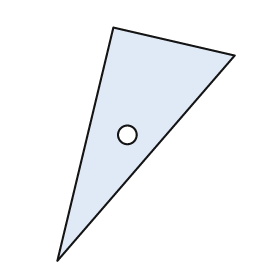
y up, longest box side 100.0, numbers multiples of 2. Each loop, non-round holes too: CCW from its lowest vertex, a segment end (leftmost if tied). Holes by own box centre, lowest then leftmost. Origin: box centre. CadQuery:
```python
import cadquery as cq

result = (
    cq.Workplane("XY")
    .moveTo(-38.0, -50.0)
    .lineTo(38.0, 38.0)
    .lineTo(-14.0, 50.0)
    .close()
    .moveTo(-8.0, 4.0)
    .circle(4.0)
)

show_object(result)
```